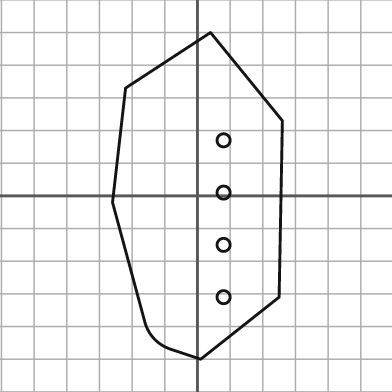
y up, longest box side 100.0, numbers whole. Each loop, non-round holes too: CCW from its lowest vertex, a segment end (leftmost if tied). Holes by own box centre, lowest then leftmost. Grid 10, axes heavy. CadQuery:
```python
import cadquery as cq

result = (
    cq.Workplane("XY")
    .moveTo(1.0, -50.0)
    .lineTo(25.0, -31.0)
    .lineTo(26.0, 23.0)
    .lineTo(4.0, 50.0)
    .lineTo(-22.0, 33.0)
    .lineTo(-26.0, -2.0)
    .lineTo(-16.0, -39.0)
    .threePointArc((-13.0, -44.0), (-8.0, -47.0))
    .close()
    .moveTo(8.0, -31.0)
    .circle(2.0)
    .moveTo(8.0, -15.0)
    .circle(2.0)
    .moveTo(8.0, 1.0)
    .circle(2.0)
    .moveTo(8.0, 17.0)
    .circle(2.0)
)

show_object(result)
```